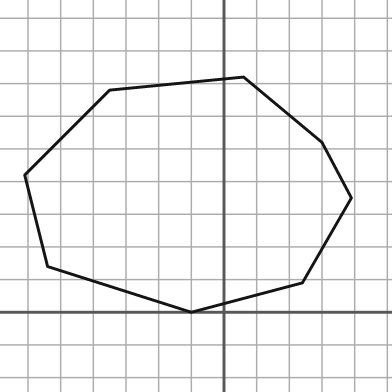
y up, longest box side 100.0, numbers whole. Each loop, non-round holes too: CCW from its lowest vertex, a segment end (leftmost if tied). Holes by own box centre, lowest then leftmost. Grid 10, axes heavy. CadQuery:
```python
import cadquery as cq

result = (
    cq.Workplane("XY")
    .moveTo(-10.0, 0.0)
    .lineTo(24.0, 9.0)
    .lineTo(39.0, 35.0)
    .lineTo(30.0, 52.0)
    .lineTo(6.0, 72.0)
    .lineTo(-35.0, 68.0)
    .lineTo(-61.0, 42.0)
    .lineTo(-54.0, 14.0)
    .close()
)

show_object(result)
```